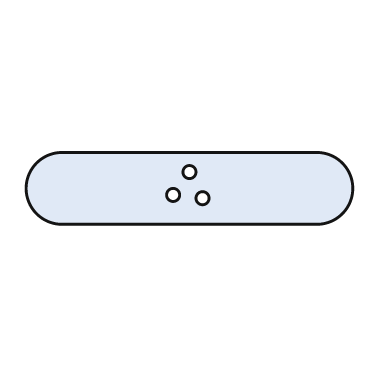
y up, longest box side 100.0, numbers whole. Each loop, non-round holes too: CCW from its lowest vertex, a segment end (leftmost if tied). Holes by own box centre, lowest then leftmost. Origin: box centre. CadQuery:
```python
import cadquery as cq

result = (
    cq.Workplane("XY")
    .moveTo(-39.0, -11.0)
    .lineTo(39.0, -11.0)
    .threePointArc((50.0, 0.0), (39.0, 11.0))
    .lineTo(-39.0, 11.0)
    .threePointArc((-50.0, 0.0), (-39.0, -11.0))
    .close()
    .moveTo(4.0, -3.0)
    .circle(2.0)
    .moveTo(-5.0, -2.0)
    .circle(2.0)
    .moveTo(0.0, 5.0)
    .circle(2.0)
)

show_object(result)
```